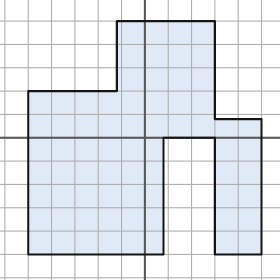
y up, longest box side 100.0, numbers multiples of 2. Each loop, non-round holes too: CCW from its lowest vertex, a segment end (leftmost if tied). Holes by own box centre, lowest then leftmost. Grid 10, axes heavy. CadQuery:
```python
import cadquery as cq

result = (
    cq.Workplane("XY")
    .moveTo(-50.0, -50.0)
    .lineTo(8.0, -50.0)
    .lineTo(8.0, 0.0)
    .lineTo(30.0, 0.0)
    .lineTo(30.0, -50.0)
    .lineTo(50.0, -50.0)
    .lineTo(50.0, 8.0)
    .lineTo(30.0, 8.0)
    .lineTo(30.0, 50.0)
    .lineTo(-12.0, 50.0)
    .lineTo(-12.0, 20.0)
    .lineTo(-50.0, 20.0)
    .close()
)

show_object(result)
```